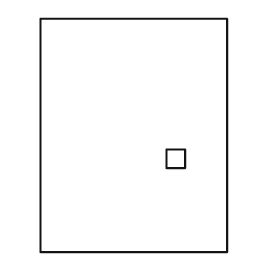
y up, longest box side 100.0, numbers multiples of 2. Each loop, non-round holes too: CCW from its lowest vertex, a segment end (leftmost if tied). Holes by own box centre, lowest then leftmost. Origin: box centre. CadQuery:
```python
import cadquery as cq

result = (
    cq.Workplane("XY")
    .moveTo(-40.0, -50.0)
    .lineTo(40.0, -50.0)
    .lineTo(40.0, 50.0)
    .lineTo(-40.0, 50.0)
    .close()
    .moveTo(14.0, -14.0)
    .lineTo(22.0, -14.0)
    .lineTo(22.0, -6.0)
    .lineTo(14.0, -6.0)
    .close()
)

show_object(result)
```